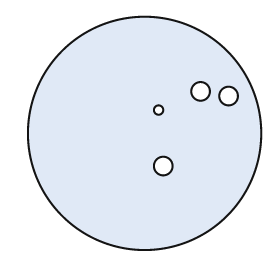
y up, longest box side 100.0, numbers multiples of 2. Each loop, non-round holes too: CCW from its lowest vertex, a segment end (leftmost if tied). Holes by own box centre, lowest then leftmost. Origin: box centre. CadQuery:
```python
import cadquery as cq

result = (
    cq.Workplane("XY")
    .moveTo(0.0, 0.0)
    .circle(50.0)
    .moveTo(8.0, -14.0)
    .circle(4.0)
    .moveTo(6.0, 10.0)
    .circle(2.0)
    .moveTo(36.0, 16.0)
    .circle(4.0)
    .moveTo(24.0, 18.0)
    .circle(4.0)
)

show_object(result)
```